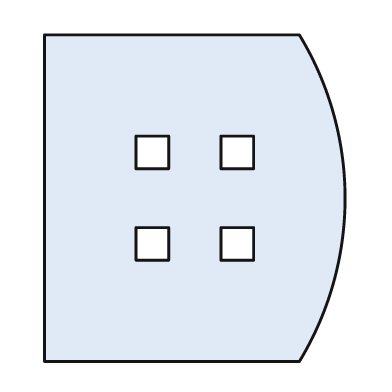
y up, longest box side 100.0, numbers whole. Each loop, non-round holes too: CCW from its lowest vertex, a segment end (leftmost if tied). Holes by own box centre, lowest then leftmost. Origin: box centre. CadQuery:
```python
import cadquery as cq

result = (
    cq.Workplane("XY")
    .moveTo(-46.0, -50.0)
    .lineTo(32.0, -50.0)
    .threePointArc((46.0, 0.0), (32.0, 50.0))
    .lineTo(-46.0, 50.0)
    .close()
    .moveTo(-18.0, -19.0)
    .lineTo(-8.0, -19.0)
    .lineTo(-8.0, -9.0)
    .lineTo(-18.0, -9.0)
    .close()
    .moveTo(8.0, -19.0)
    .lineTo(18.0, -19.0)
    .lineTo(18.0, -9.0)
    .lineTo(8.0, -9.0)
    .close()
    .moveTo(-18.0, 9.0)
    .lineTo(-8.0, 9.0)
    .lineTo(-8.0, 19.0)
    .lineTo(-18.0, 19.0)
    .close()
    .moveTo(8.0, 9.0)
    .lineTo(18.0, 9.0)
    .lineTo(18.0, 19.0)
    .lineTo(8.0, 19.0)
    .close()
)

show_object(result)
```